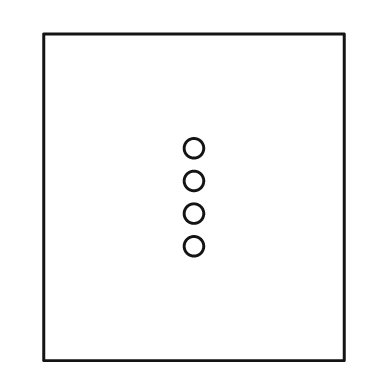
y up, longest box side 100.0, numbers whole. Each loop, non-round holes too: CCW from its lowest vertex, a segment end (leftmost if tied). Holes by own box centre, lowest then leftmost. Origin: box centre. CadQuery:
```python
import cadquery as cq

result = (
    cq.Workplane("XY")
    .moveTo(-46.0, -50.0)
    .lineTo(46.0, -50.0)
    .lineTo(46.0, 50.0)
    .lineTo(-46.0, 50.0)
    .close()
    .moveTo(0.0, -15.0)
    .circle(3.0)
    .moveTo(0.0, -5.0)
    .circle(3.0)
    .moveTo(0.0, 5.0)
    .circle(3.0)
    .moveTo(0.0, 15.0)
    .circle(3.0)
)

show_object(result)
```